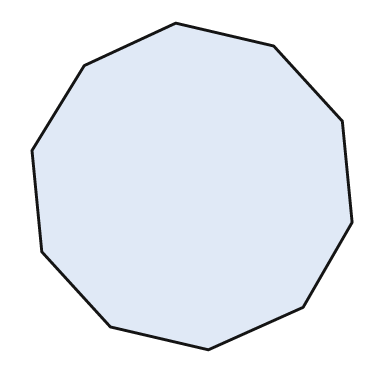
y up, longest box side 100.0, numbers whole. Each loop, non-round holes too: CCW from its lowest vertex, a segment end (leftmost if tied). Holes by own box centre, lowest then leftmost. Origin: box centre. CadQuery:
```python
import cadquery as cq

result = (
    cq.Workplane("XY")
    .moveTo(5.0, -50.0)
    .lineTo(34.0, -37.0)
    .lineTo(49.0, -11.0)
    .lineTo(46.0, 20.0)
    .lineTo(25.0, 43.0)
    .lineTo(-5.0, 50.0)
    .lineTo(-33.0, 37.0)
    .lineTo(-49.0, 11.0)
    .lineTo(-46.0, -20.0)
    .lineTo(-25.0, -43.0)
    .close()
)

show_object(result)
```